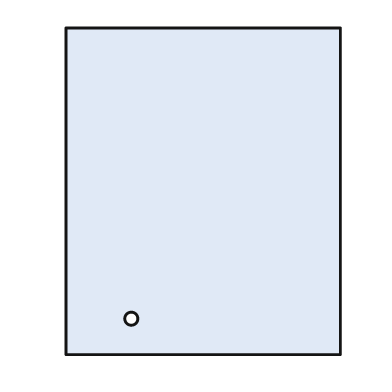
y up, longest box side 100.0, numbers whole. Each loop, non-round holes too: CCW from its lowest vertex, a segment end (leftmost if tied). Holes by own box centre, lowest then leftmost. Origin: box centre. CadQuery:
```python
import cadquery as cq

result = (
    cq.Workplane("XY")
    .moveTo(-42.0, -50.0)
    .lineTo(42.0, -50.0)
    .lineTo(42.0, 50.0)
    .lineTo(-42.0, 50.0)
    .close()
    .moveTo(-22.0, -39.0)
    .circle(2.0)
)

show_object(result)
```